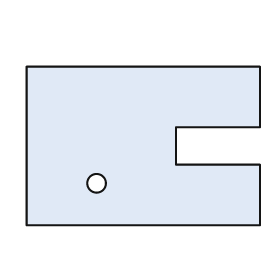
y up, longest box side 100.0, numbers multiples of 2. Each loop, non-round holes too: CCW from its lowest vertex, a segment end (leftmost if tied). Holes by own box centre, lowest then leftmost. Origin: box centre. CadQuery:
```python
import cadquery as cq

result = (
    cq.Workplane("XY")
    .moveTo(-50.0, -34.0)
    .lineTo(50.0, -34.0)
    .lineTo(50.0, -8.0)
    .lineTo(14.0, -8.0)
    .lineTo(14.0, 8.0)
    .lineTo(50.0, 8.0)
    .lineTo(50.0, 34.0)
    .lineTo(-50.0, 34.0)
    .close()
    .moveTo(-20.0, -16.0)
    .circle(4.0)
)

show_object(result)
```